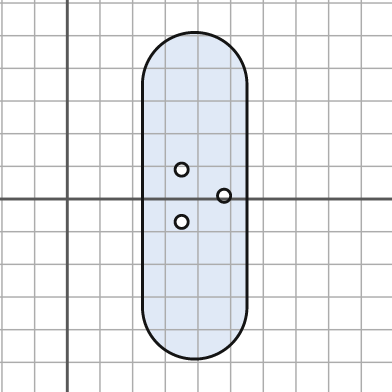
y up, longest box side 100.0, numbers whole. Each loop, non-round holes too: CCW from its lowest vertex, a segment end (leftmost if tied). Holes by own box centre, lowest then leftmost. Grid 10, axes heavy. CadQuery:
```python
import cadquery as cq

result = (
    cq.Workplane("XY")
    .moveTo(23.0, -33.0)
    .threePointArc((39.0, -49.0), (55.0, -33.0))
    .lineTo(55.0, 35.0)
    .threePointArc((39.0, 51.0), (23.0, 35.0))
    .close()
    .moveTo(35.0, -7.0)
    .circle(2.0)
    .moveTo(48.0, 1.0)
    .circle(2.0)
    .moveTo(35.0, 9.0)
    .circle(2.0)
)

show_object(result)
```